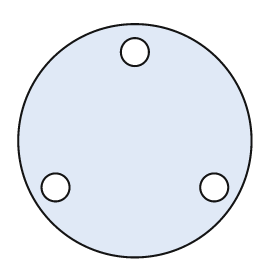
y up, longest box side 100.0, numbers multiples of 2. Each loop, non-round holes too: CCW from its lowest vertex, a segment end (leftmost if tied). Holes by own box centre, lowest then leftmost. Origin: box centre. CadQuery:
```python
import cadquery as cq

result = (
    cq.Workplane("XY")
    .moveTo(0.0, 0.0)
    .circle(50.0)
    .moveTo(-34.0, -20.0)
    .circle(6.0)
    .moveTo(34.0, -20.0)
    .circle(6.0)
    .moveTo(0.0, 38.0)
    .circle(6.0)
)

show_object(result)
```